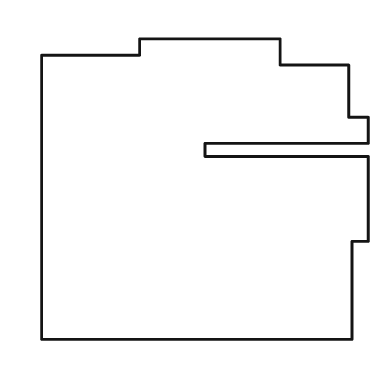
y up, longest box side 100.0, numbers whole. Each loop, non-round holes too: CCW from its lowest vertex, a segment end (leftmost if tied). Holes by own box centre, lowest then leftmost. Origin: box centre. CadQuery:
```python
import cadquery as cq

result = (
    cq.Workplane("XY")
    .moveTo(-50.0, -46.0)
    .lineTo(45.0, -46.0)
    .lineTo(45.0, -16.0)
    .lineTo(50.0, -16.0)
    .lineTo(50.0, 10.0)
    .lineTo(0.0, 10.0)
    .lineTo(0.0, 14.0)
    .lineTo(50.0, 14.0)
    .lineTo(50.0, 22.0)
    .lineTo(44.0, 22.0)
    .lineTo(44.0, 38.0)
    .lineTo(23.0, 38.0)
    .lineTo(23.0, 46.0)
    .lineTo(-20.0, 46.0)
    .lineTo(-20.0, 41.0)
    .lineTo(-50.0, 41.0)
    .close()
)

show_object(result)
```